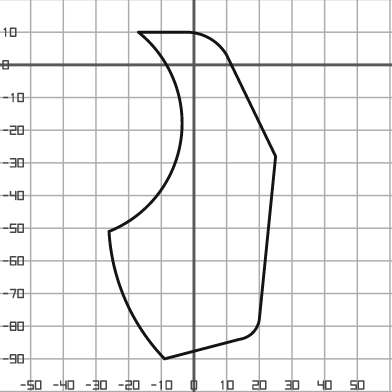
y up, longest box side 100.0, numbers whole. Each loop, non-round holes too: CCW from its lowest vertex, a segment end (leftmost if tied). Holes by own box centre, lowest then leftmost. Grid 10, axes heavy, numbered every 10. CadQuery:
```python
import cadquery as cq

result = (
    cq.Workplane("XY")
    .moveTo(-9.0, -90.0)
    .lineTo(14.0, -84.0)
    .threePointArc((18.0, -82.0), (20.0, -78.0))
    .lineTo(25.0, -28.0)
    .lineTo(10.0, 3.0)
    .threePointArc((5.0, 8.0), (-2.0, 10.0))
    .lineTo(-17.0, 10.0)
    .threePointArc((-4.0, -23.0), (-26.0, -51.0))
    .threePointArc((-21.0, -72.0), (-9.0, -90.0))
    .close()
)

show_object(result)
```